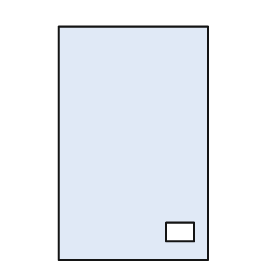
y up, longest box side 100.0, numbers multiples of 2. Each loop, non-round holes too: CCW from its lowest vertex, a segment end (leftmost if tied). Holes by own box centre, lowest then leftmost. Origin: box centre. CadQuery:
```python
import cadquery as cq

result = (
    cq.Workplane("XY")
    .moveTo(-32.0, -50.0)
    .lineTo(32.0, -50.0)
    .lineTo(32.0, 50.0)
    .lineTo(-32.0, 50.0)
    .close()
    .moveTo(14.0, -42.0)
    .lineTo(26.0, -42.0)
    .lineTo(26.0, -34.0)
    .lineTo(14.0, -34.0)
    .close()
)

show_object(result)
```